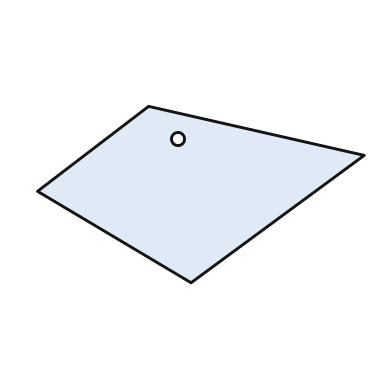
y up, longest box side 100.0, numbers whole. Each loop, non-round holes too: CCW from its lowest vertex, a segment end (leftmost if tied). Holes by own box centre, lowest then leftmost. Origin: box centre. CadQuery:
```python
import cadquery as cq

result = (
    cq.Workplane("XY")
    .moveTo(-3.0, -27.0)
    .lineTo(50.0, 12.0)
    .lineTo(-16.0, 27.0)
    .lineTo(-50.0, 1.0)
    .close()
    .moveTo(-7.0, 17.0)
    .circle(2.0)
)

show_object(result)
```